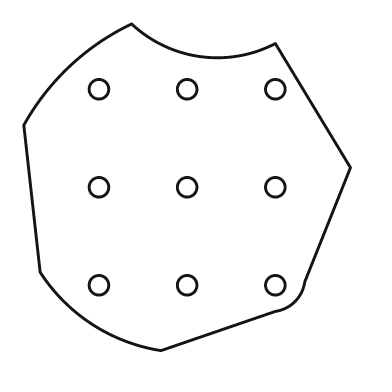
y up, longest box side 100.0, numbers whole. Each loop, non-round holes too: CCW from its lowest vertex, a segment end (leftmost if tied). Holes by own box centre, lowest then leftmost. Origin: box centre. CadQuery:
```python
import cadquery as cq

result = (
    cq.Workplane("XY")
    .moveTo(-8.0, -50.0)
    .lineTo(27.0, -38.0)
    .threePointArc((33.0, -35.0), (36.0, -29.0))
    .lineTo(50.0, 6.0)
    .lineTo(27.0, 44.0)
    .threePointArc((4.0, 40.0), (-17.0, 50.0))
    .threePointArc((-36.0, 37.0), (-50.0, 19.0))
    .lineTo(-45.0, -26.0)
    .threePointArc((-29.0, -42.0), (-8.0, -50.0))
    .close()
    .moveTo(-27.0, -30.0)
    .circle(3.0)
    .moveTo(0.0, -30.0)
    .circle(3.0)
    .moveTo(27.0, -30.0)
    .circle(3.0)
    .moveTo(-27.0, 0.0)
    .circle(3.0)
    .moveTo(0.0, 0.0)
    .circle(3.0)
    .moveTo(27.0, 0.0)
    .circle(3.0)
    .moveTo(-27.0, 30.0)
    .circle(3.0)
    .moveTo(0.0, 30.0)
    .circle(3.0)
    .moveTo(27.0, 30.0)
    .circle(3.0)
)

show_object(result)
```